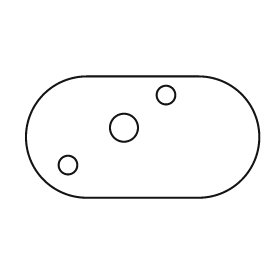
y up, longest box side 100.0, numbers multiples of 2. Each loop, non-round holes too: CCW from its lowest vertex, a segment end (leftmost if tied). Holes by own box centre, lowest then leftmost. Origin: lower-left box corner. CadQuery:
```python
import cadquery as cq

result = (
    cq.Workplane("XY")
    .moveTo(26.0, 0.0)
    .lineTo(74.0, 0.0)
    .threePointArc((100.0, 26.0), (74.0, 52.0))
    .lineTo(26.0, 52.0)
    .threePointArc((0.0, 26.0), (26.0, 0.0))
    .close()
    .moveTo(18.0, 14.0)
    .circle(4.0)
    .moveTo(42.0, 30.0)
    .circle(6.0)
    .moveTo(60.0, 44.0)
    .circle(4.0)
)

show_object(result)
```